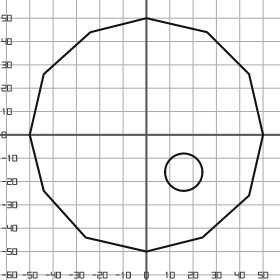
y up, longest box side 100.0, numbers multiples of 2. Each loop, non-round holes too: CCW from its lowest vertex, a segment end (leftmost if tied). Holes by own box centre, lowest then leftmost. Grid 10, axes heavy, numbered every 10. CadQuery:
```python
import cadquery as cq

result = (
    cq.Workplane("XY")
    .moveTo(0.0, -50.0)
    .lineTo(24.0, -44.0)
    .lineTo(44.0, -26.0)
    .lineTo(50.0, 0.0)
    .lineTo(44.0, 26.0)
    .lineTo(26.0, 44.0)
    .lineTo(0.0, 50.0)
    .lineTo(-24.0, 44.0)
    .lineTo(-44.0, 26.0)
    .lineTo(-50.0, 0.0)
    .lineTo(-44.0, -24.0)
    .lineTo(-26.0, -44.0)
    .close()
    .moveTo(16.0, -16.0)
    .circle(8.0)
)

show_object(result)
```